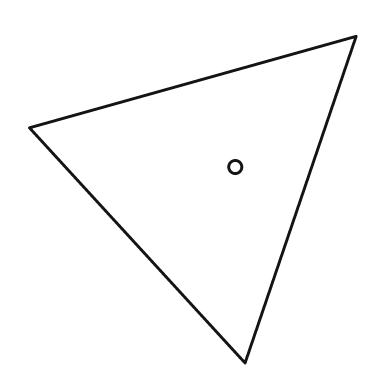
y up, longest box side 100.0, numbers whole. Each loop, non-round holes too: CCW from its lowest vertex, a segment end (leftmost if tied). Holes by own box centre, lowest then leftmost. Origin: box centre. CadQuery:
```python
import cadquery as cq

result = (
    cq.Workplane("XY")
    .moveTo(16.0, -50.0)
    .lineTo(50.0, 50.0)
    .lineTo(-50.0, 22.0)
    .close()
    .moveTo(13.0, 10.0)
    .circle(2.0)
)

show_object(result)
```